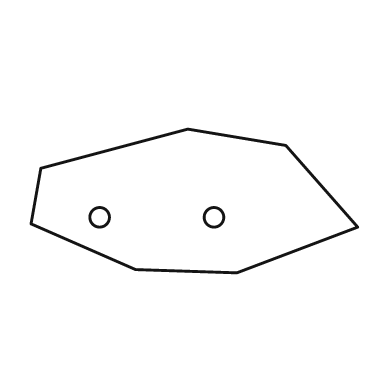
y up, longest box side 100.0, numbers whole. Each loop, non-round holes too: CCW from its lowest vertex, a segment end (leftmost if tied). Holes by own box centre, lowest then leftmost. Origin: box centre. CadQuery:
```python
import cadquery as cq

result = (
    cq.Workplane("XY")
    .moveTo(13.0, -22.0)
    .lineTo(50.0, -8.0)
    .lineTo(28.0, 17.0)
    .lineTo(-2.0, 22.0)
    .lineTo(-47.0, 10.0)
    .lineTo(-50.0, -7.0)
    .lineTo(-18.0, -21.0)
    .close()
    .moveTo(-29.0, -5.0)
    .circle(3.0)
    .moveTo(6.0, -5.0)
    .circle(3.0)
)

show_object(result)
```